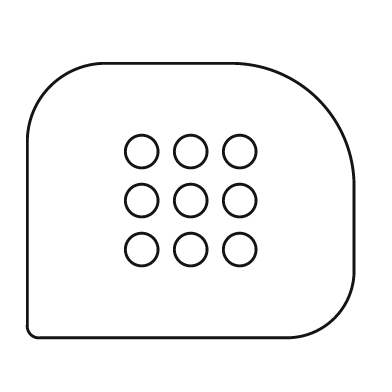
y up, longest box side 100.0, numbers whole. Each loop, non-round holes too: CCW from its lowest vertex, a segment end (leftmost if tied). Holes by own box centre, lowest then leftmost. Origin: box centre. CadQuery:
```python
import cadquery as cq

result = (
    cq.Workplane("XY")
    .moveTo(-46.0, -42.0)
    .lineTo(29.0, -42.0)
    .threePointArc((44.0, -36.0), (50.0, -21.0))
    .lineTo(50.0, 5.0)
    .threePointArc((39.0, 31.0), (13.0, 42.0))
    .lineTo(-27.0, 42.0)
    .threePointArc((-43.0, 35.0), (-50.0, 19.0))
    .lineTo(-50.0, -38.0)
    .threePointArc((-49.0, -41.0), (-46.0, -42.0))
    .close()
    .moveTo(-15.0, -15.0)
    .circle(5.0)
    .moveTo(0.0, -15.0)
    .circle(5.0)
    .moveTo(15.0, -15.0)
    .circle(5.0)
    .moveTo(-15.0, 0.0)
    .circle(5.0)
    .moveTo(0.0, 0.0)
    .circle(5.0)
    .moveTo(15.0, 0.0)
    .circle(5.0)
    .moveTo(-15.0, 15.0)
    .circle(5.0)
    .moveTo(0.0, 15.0)
    .circle(5.0)
    .moveTo(15.0, 15.0)
    .circle(5.0)
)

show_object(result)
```